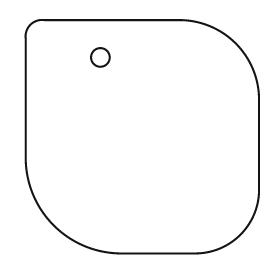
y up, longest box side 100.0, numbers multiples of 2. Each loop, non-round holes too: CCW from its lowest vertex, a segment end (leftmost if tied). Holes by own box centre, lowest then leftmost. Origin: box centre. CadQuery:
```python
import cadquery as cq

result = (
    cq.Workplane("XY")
    .moveTo(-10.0, -50.0)
    .lineTo(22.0, -50.0)
    .threePointArc((42.0, -42.0), (50.0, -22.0))
    .lineTo(50.0, 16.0)
    .threePointArc((40.0, 40.0), (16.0, 50.0))
    .lineTo(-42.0, 50.0)
    .threePointArc((-48.0, 48.0), (-50.0, 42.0))
    .lineTo(-50.0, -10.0)
    .threePointArc((-38.0, -38.0), (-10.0, -50.0))
    .close()
    .moveTo(-18.0, 34.0)
    .circle(4.0)
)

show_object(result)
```